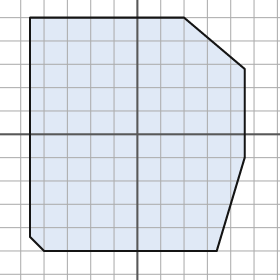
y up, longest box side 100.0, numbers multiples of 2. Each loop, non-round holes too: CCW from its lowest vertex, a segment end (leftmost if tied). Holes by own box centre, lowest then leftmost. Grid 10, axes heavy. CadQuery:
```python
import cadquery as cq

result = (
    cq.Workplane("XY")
    .moveTo(-40.0, -50.0)
    .lineTo(34.0, -50.0)
    .lineTo(46.0, -10.0)
    .lineTo(46.0, 28.0)
    .lineTo(20.0, 50.0)
    .lineTo(-46.0, 50.0)
    .lineTo(-46.0, -44.0)
    .close()
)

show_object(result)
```